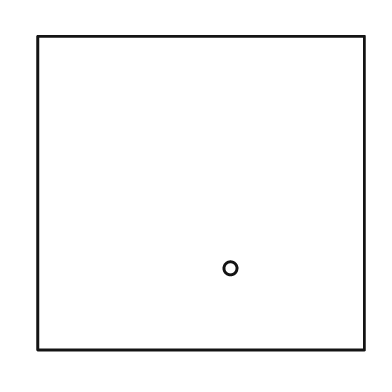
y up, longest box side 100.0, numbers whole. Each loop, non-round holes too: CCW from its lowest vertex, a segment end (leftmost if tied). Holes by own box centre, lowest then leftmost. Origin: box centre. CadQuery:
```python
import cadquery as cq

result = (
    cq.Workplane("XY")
    .moveTo(-50.0, -48.0)
    .lineTo(50.0, -48.0)
    .lineTo(50.0, 48.0)
    .lineTo(-50.0, 48.0)
    .close()
    .moveTo(9.0, -23.0)
    .circle(2.0)
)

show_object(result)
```